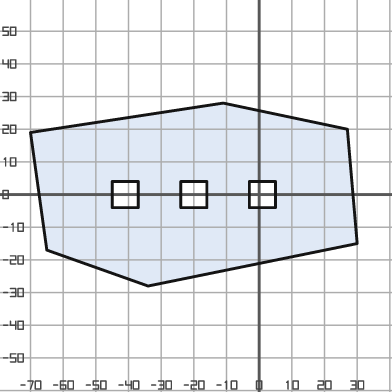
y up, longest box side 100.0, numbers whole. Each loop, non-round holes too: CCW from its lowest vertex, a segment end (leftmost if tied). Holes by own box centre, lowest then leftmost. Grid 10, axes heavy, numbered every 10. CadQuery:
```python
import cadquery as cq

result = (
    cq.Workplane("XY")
    .moveTo(-34.0, -28.0)
    .lineTo(30.0, -15.0)
    .lineTo(27.0, 20.0)
    .lineTo(-11.0, 28.0)
    .lineTo(-70.0, 19.0)
    .lineTo(-65.0, -17.0)
    .close()
    .moveTo(-45.0, -4.0)
    .lineTo(-37.0, -4.0)
    .lineTo(-37.0, 4.0)
    .lineTo(-45.0, 4.0)
    .close()
    .moveTo(-24.0, -4.0)
    .lineTo(-16.0, -4.0)
    .lineTo(-16.0, 4.0)
    .lineTo(-24.0, 4.0)
    .close()
    .moveTo(-3.0, -4.0)
    .lineTo(5.0, -4.0)
    .lineTo(5.0, 4.0)
    .lineTo(-3.0, 4.0)
    .close()
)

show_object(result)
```